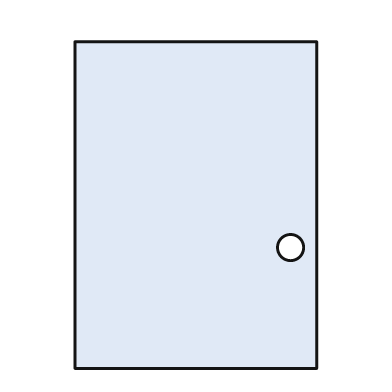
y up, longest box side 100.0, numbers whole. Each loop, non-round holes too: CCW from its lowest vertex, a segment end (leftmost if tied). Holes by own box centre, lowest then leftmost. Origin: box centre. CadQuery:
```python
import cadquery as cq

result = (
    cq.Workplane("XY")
    .moveTo(-37.0, -50.0)
    .lineTo(37.0, -50.0)
    .lineTo(37.0, 50.0)
    .lineTo(-37.0, 50.0)
    .close()
    .moveTo(29.0, -13.0)
    .circle(4.0)
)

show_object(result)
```